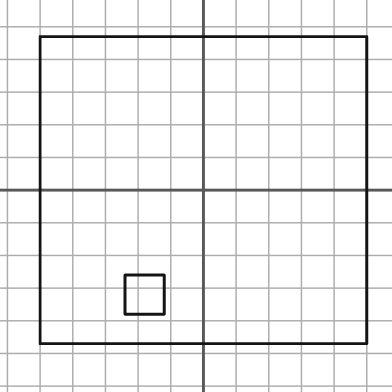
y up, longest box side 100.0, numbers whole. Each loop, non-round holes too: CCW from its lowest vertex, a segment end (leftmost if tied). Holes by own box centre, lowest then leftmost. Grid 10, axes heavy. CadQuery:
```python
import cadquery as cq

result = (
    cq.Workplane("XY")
    .moveTo(-50.0, -47.0)
    .lineTo(50.0, -47.0)
    .lineTo(50.0, 47.0)
    .lineTo(-50.0, 47.0)
    .close()
    .moveTo(-24.0, -38.0)
    .lineTo(-12.0, -38.0)
    .lineTo(-12.0, -26.0)
    .lineTo(-24.0, -26.0)
    .close()
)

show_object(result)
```